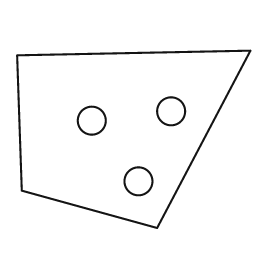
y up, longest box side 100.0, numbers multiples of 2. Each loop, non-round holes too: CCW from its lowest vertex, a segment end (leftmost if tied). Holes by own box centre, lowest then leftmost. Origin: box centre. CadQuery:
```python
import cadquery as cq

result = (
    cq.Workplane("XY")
    .moveTo(10.0, -38.0)
    .lineTo(50.0, 38.0)
    .lineTo(-50.0, 36.0)
    .lineTo(-48.0, -22.0)
    .close()
    .moveTo(2.0, -18.0)
    .circle(6.0)
    .moveTo(-18.0, 8.0)
    .circle(6.0)
    .moveTo(16.0, 12.0)
    .circle(6.0)
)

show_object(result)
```